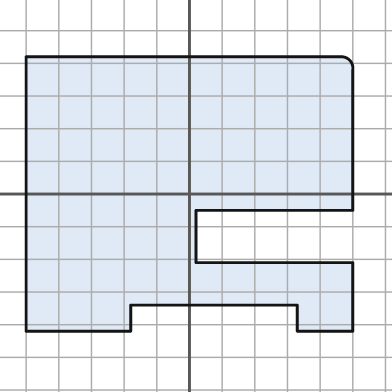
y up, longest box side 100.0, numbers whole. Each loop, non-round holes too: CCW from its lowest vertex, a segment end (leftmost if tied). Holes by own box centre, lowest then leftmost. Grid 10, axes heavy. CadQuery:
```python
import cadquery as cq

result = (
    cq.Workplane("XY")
    .moveTo(-50.0, -42.0)
    .lineTo(-18.0, -42.0)
    .lineTo(-18.0, -34.0)
    .lineTo(33.0, -34.0)
    .lineTo(33.0, -42.0)
    .lineTo(50.0, -42.0)
    .lineTo(50.0, -21.0)
    .lineTo(2.0, -21.0)
    .lineTo(2.0, -5.0)
    .lineTo(50.0, -5.0)
    .lineTo(50.0, 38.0)
    .threePointArc((49.0, 41.0), (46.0, 42.0))
    .lineTo(-50.0, 42.0)
    .close()
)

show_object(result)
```